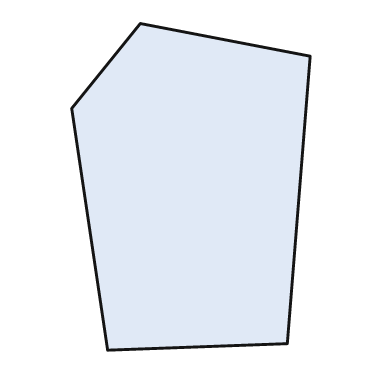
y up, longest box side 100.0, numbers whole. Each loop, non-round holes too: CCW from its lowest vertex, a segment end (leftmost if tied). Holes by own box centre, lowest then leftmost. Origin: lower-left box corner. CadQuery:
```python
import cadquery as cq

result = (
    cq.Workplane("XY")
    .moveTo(11.0, 0.0)
    .lineTo(66.0, 2.0)
    .lineTo(73.0, 90.0)
    .lineTo(21.0, 100.0)
    .lineTo(0.0, 74.0)
    .close()
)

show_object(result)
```